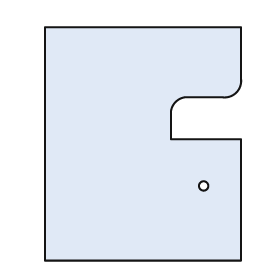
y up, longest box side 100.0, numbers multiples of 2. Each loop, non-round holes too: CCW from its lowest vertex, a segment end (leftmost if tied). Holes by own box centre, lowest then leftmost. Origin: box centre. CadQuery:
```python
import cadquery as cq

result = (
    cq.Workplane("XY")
    .moveTo(-42.0, -50.0)
    .lineTo(42.0, -50.0)
    .lineTo(42.0, 2.0)
    .lineTo(12.0, 2.0)
    .lineTo(12.0, 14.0)
    .threePointArc((14.0, 18.0), (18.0, 20.0))
    .lineTo(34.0, 20.0)
    .threePointArc((40.0, 22.0), (42.0, 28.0))
    .lineTo(42.0, 50.0)
    .lineTo(-42.0, 50.0)
    .close()
    .moveTo(26.0, -18.0)
    .circle(2.0)
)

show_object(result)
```